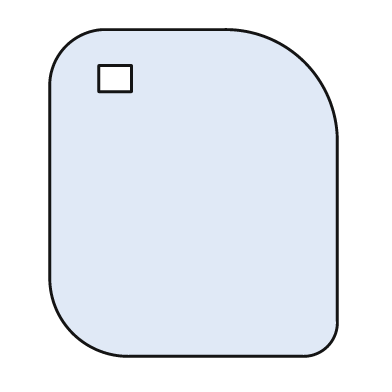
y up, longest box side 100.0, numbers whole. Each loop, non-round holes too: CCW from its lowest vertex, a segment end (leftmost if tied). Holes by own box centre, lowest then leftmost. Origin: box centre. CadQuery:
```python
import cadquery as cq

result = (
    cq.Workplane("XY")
    .moveTo(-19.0, -50.0)
    .lineTo(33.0, -50.0)
    .threePointArc((41.0, -47.0), (44.0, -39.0))
    .lineTo(44.0, 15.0)
    .threePointArc((34.0, 40.0), (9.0, 50.0))
    .lineTo(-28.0, 50.0)
    .threePointArc((-39.0, 45.0), (-44.0, 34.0))
    .lineTo(-44.0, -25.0)
    .threePointArc((-37.0, -43.0), (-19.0, -50.0))
    .close()
    .moveTo(-29.0, 31.0)
    .lineTo(-19.0, 31.0)
    .lineTo(-19.0, 39.0)
    .lineTo(-29.0, 39.0)
    .close()
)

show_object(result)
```